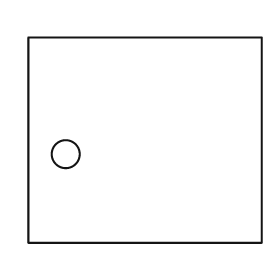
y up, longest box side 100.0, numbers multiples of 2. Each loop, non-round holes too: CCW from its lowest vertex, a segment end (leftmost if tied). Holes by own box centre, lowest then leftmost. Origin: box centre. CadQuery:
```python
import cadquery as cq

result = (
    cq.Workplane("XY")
    .moveTo(-50.0, -44.0)
    .lineTo(50.0, -44.0)
    .lineTo(50.0, 44.0)
    .lineTo(-50.0, 44.0)
    .close()
    .moveTo(-34.0, -6.0)
    .circle(6.0)
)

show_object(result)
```